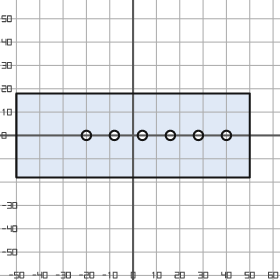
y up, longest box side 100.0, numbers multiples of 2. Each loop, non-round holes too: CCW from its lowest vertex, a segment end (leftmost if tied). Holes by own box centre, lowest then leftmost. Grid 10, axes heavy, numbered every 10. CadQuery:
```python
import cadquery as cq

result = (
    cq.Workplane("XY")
    .moveTo(-50.0, -18.0)
    .lineTo(50.0, -18.0)
    .lineTo(50.0, 18.0)
    .lineTo(-50.0, 18.0)
    .close()
    .moveTo(-20.0, 0.0)
    .circle(2.0)
    .moveTo(-8.0, 0.0)
    .circle(2.0)
    .moveTo(4.0, 0.0)
    .circle(2.0)
    .moveTo(16.0, 0.0)
    .circle(2.0)
    .moveTo(28.0, 0.0)
    .circle(2.0)
    .moveTo(40.0, 0.0)
    .circle(2.0)
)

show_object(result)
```